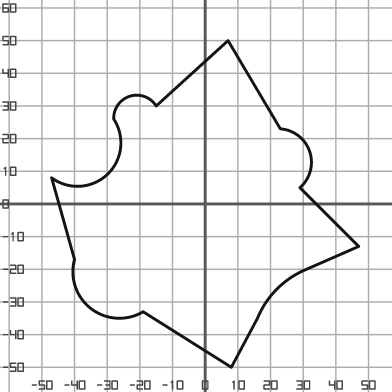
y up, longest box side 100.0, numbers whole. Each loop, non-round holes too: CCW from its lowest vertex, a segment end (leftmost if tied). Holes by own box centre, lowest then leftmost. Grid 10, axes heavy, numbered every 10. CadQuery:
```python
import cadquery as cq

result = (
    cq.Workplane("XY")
    .moveTo(8.0, -50.0)
    .lineTo(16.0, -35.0)
    .threePointArc((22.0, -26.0), (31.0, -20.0))
    .lineTo(47.0, -13.0)
    .lineTo(29.0, 5.0)
    .threePointArc((32.0, 16.0), (23.0, 23.0))
    .lineTo(7.0, 50.0)
    .lineTo(-15.0, 30.0)
    .threePointArc((-23.0, 33.0), (-28.0, 26.0))
    .threePointArc((-30.0, 9.0), (-47.0, 8.0))
    .lineTo(-40.0, -17.0)
    .threePointArc((-35.0, -32.0), (-19.0, -33.0))
    .close()
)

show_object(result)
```